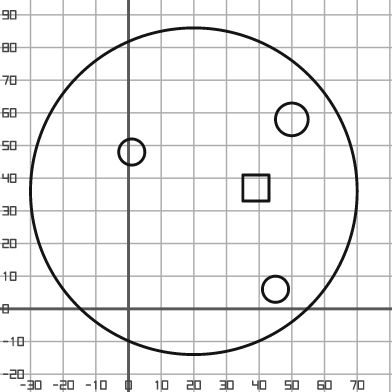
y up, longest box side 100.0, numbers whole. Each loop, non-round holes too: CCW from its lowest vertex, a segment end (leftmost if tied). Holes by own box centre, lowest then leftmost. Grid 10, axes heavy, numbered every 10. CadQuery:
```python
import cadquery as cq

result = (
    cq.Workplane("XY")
    .moveTo(20.0, 36.0)
    .circle(50.0)
    .moveTo(45.0, 6.0)
    .circle(4.0)
    .moveTo(35.0, 33.0)
    .lineTo(43.0, 33.0)
    .lineTo(43.0, 41.0)
    .lineTo(35.0, 41.0)
    .close()
    .moveTo(1.0, 48.0)
    .circle(4.0)
    .moveTo(50.0, 58.0)
    .circle(5.0)
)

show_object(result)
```